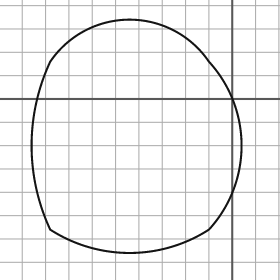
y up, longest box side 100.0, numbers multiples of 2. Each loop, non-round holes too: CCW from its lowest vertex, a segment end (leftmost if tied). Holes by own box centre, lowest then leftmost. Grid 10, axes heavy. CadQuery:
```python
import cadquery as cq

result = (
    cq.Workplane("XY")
    .moveTo(-78.0, -56.0)
    .threePointArc((-44.0, -66.0), (-10.0, -56.0))
    .threePointArc((4.0, -20.0), (-10.0, 16.0))
    .threePointArc((-44.0, 34.0), (-78.0, 16.0))
    .threePointArc((-86.0, -20.0), (-78.0, -56.0))
    .close()
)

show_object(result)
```